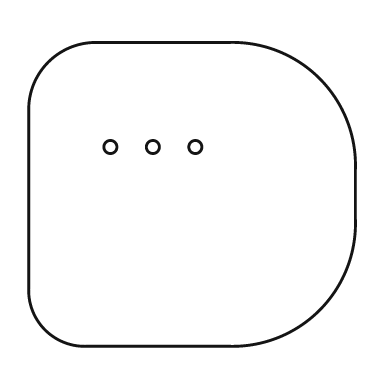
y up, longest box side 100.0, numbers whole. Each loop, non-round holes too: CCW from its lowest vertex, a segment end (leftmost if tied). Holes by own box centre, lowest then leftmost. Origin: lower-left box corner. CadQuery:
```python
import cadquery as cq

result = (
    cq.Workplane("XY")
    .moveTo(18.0, 0.0)
    .lineTo(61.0, 0.0)
    .threePointArc((89.0, 11.0), (100.0, 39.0))
    .lineTo(100.0, 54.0)
    .threePointArc((89.0, 82.0), (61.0, 93.0))
    .lineTo(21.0, 93.0)
    .threePointArc((6.0, 87.0), (0.0, 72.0))
    .lineTo(0.0, 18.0)
    .threePointArc((5.0, 5.0), (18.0, 0.0))
    .close()
    .moveTo(25.0, 61.0)
    .circle(2.0)
    .moveTo(38.0, 61.0)
    .circle(2.0)
    .moveTo(51.0, 61.0)
    .circle(2.0)
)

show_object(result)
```